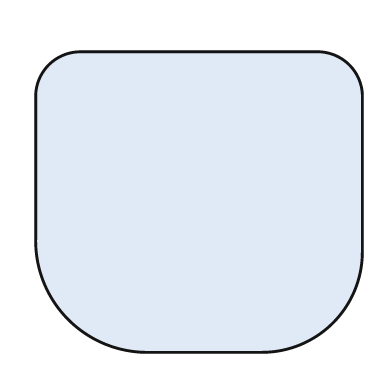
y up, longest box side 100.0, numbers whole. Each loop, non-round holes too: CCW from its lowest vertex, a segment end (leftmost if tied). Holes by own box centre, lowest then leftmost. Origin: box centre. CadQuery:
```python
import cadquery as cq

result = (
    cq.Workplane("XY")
    .moveTo(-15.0, -46.0)
    .lineTo(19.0, -46.0)
    .threePointArc((41.0, -37.0), (50.0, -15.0))
    .lineTo(50.0, 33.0)
    .threePointArc((46.0, 42.0), (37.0, 46.0))
    .lineTo(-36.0, 46.0)
    .threePointArc((-46.0, 42.0), (-50.0, 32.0))
    .lineTo(-50.0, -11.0)
    .threePointArc((-40.0, -36.0), (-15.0, -46.0))
    .close()
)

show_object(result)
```